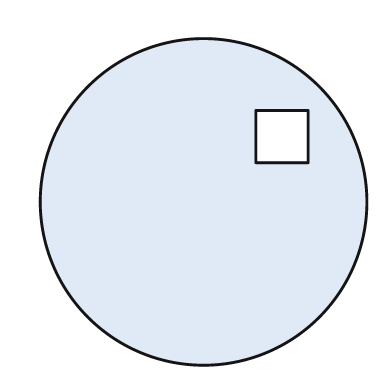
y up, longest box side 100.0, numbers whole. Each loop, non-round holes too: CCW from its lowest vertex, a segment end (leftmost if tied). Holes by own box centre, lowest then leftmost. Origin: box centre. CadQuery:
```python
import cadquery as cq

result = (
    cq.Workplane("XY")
    .moveTo(0.0, 0.0)
    .circle(50.0)
    .moveTo(16.0, 12.0)
    .lineTo(32.0, 12.0)
    .lineTo(32.0, 28.0)
    .lineTo(16.0, 28.0)
    .close()
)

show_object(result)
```